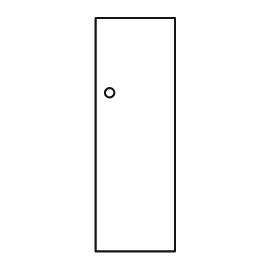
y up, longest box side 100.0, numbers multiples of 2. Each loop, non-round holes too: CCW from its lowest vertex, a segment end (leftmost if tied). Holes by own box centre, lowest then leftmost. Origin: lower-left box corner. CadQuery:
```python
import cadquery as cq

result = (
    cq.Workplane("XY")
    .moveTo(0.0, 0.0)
    .lineTo(34.0, 0.0)
    .lineTo(34.0, 100.0)
    .lineTo(0.0, 100.0)
    .close()
    .moveTo(6.0, 68.0)
    .circle(2.0)
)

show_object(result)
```